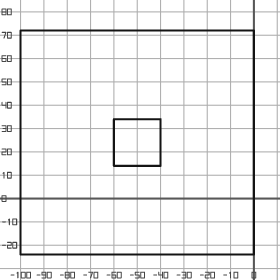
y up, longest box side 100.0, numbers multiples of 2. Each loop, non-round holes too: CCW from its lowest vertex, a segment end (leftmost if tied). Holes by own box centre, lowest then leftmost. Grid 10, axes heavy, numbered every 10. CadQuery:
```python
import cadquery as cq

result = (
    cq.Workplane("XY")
    .moveTo(-100.0, -24.0)
    .lineTo(0.0, -24.0)
    .lineTo(0.0, 72.0)
    .lineTo(-100.0, 72.0)
    .close()
    .moveTo(-60.0, 14.0)
    .lineTo(-40.0, 14.0)
    .lineTo(-40.0, 34.0)
    .lineTo(-60.0, 34.0)
    .close()
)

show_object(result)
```